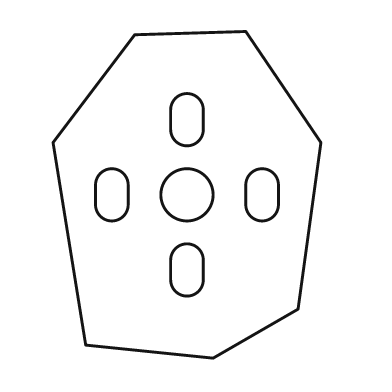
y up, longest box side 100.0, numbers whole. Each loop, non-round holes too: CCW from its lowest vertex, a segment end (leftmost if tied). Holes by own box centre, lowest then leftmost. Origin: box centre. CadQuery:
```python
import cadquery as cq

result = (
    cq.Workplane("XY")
    .moveTo(8.0, -50.0)
    .lineTo(34.0, -35.0)
    .lineTo(41.0, 16.0)
    .lineTo(18.0, 50.0)
    .lineTo(-16.0, 49.0)
    .lineTo(-41.0, 16.0)
    .lineTo(-31.0, -46.0)
    .close()
    .moveTo(-5.0, -26.0)
    .threePointArc((0.0, -31.0), (5.0, -26.0))
    .lineTo(5.0, -20.0)
    .threePointArc((0.0, -15.0), (-5.0, -20.0))
    .close()
    .moveTo(-28.0, -3.0)
    .threePointArc((-23.0, -8.0), (-18.0, -3.0))
    .lineTo(-18.0, 3.0)
    .threePointArc((-23.0, 8.0), (-28.0, 3.0))
    .close()
    .moveTo(0.0, 0.0)
    .circle(8.0)
    .moveTo(18.0, -3.0)
    .threePointArc((23.0, -8.0), (28.0, -3.0))
    .lineTo(28.0, 3.0)
    .threePointArc((23.0, 8.0), (18.0, 3.0))
    .close()
    .moveTo(-5.0, 20.0)
    .threePointArc((0.0, 15.0), (5.0, 20.0))
    .lineTo(5.0, 26.0)
    .threePointArc((0.0, 31.0), (-5.0, 26.0))
    .close()
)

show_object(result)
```